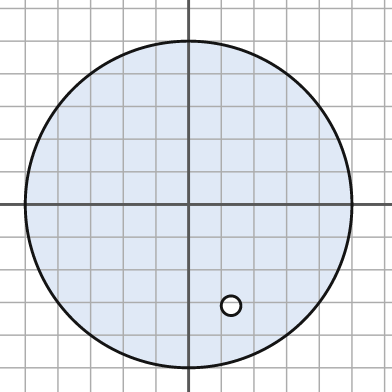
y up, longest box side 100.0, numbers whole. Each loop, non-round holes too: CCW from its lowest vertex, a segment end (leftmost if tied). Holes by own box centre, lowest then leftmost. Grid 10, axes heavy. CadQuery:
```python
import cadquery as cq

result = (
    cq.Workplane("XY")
    .moveTo(0.0, 0.0)
    .circle(50.0)
    .moveTo(13.0, -31.0)
    .circle(3.0)
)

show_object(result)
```